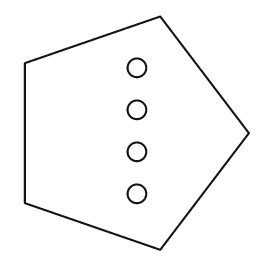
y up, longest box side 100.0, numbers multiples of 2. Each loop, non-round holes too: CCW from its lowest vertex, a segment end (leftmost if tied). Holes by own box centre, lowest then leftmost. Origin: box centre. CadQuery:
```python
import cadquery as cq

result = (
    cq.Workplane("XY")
    .moveTo(10.0, -50.0)
    .lineTo(48.0, 0.0)
    .lineTo(10.0, 50.0)
    .lineTo(-48.0, 30.0)
    .lineTo(-48.0, -30.0)
    .close()
    .moveTo(0.0, -26.0)
    .circle(4.0)
    .moveTo(0.0, -8.0)
    .circle(4.0)
    .moveTo(0.0, 10.0)
    .circle(4.0)
    .moveTo(0.0, 28.0)
    .circle(4.0)
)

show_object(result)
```